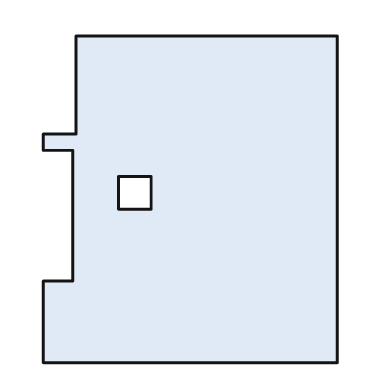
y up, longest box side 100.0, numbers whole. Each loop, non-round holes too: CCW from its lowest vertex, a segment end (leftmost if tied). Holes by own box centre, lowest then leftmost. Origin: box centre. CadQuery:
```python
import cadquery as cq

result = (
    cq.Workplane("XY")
    .moveTo(-45.0, -50.0)
    .lineTo(45.0, -50.0)
    .lineTo(45.0, 50.0)
    .lineTo(-35.0, 50.0)
    .lineTo(-35.0, 20.0)
    .lineTo(-45.0, 20.0)
    .lineTo(-45.0, 15.0)
    .lineTo(-36.0, 15.0)
    .lineTo(-36.0, -25.0)
    .lineTo(-45.0, -25.0)
    .close()
    .moveTo(-22.0, -3.0)
    .lineTo(-12.0, -3.0)
    .lineTo(-12.0, 7.0)
    .lineTo(-22.0, 7.0)
    .close()
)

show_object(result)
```